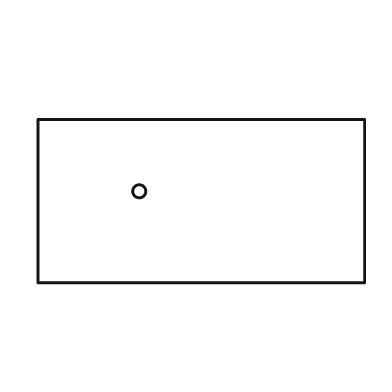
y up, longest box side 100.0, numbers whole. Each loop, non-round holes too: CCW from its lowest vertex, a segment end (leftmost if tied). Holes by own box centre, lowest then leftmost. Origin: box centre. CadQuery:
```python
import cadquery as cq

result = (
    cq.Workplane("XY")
    .moveTo(-50.0, -25.0)
    .lineTo(50.0, -25.0)
    .lineTo(50.0, 25.0)
    .lineTo(-50.0, 25.0)
    .close()
    .moveTo(-19.0, 3.0)
    .circle(2.0)
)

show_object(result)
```